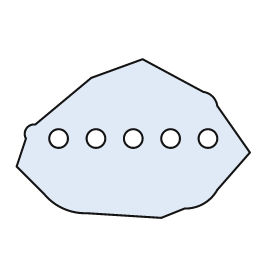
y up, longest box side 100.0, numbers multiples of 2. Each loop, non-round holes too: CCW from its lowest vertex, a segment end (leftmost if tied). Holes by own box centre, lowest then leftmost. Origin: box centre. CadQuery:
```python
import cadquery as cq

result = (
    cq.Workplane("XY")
    .moveTo(12.0, -34.0)
    .lineTo(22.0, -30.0)
    .threePointArc((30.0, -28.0), (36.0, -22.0))
    .lineTo(50.0, -6.0)
    .lineTo(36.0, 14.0)
    .threePointArc((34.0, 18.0), (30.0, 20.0))
    .lineTo(4.0, 34.0)
    .lineTo(-18.0, 26.0)
    .lineTo(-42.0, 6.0)
    .threePointArc((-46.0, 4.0), (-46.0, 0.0))
    .lineTo(-50.0, -12.0)
    .lineTo(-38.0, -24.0)
    .threePointArc((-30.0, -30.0), (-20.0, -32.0))
    .close()
    .moveTo(-32.0, 0.0)
    .circle(4.0)
    .moveTo(-16.0, 0.0)
    .circle(4.0)
    .moveTo(0.0, 0.0)
    .circle(4.0)
    .moveTo(16.0, 0.0)
    .circle(4.0)
    .moveTo(32.0, 0.0)
    .circle(4.0)
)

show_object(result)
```